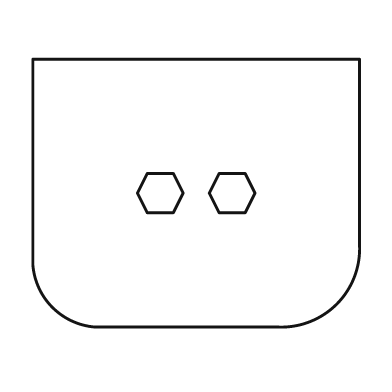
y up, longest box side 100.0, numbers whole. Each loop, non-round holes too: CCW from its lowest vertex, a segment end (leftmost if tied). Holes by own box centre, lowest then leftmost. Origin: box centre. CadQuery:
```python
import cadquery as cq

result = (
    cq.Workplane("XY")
    .moveTo(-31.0, -41.0)
    .lineTo(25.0, -41.0)
    .threePointArc((43.0, -34.0), (50.0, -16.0))
    .lineTo(50.0, 41.0)
    .lineTo(-50.0, 41.0)
    .lineTo(-50.0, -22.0)
    .threePointArc((-44.0, -35.0), (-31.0, -41.0))
    .close()
    .moveTo(-15.0, -6.0)
    .lineTo(-7.0, -6.0)
    .lineTo(-4.0, 0.0)
    .lineTo(-7.0, 6.0)
    .lineTo(-15.0, 6.0)
    .lineTo(-18.0, 0.0)
    .close()
    .moveTo(7.0, -6.0)
    .lineTo(15.0, -6.0)
    .lineTo(18.0, 0.0)
    .lineTo(15.0, 6.0)
    .lineTo(7.0, 6.0)
    .lineTo(4.0, 0.0)
    .close()
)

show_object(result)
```